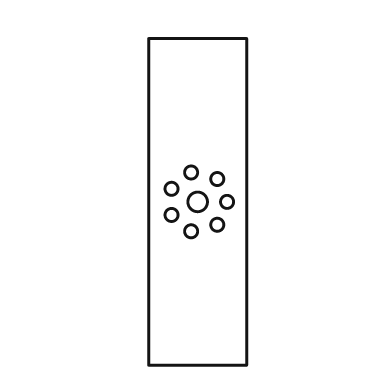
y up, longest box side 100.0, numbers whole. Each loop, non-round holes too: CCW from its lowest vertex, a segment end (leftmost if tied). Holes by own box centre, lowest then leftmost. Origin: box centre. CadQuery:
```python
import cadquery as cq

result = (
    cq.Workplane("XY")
    .moveTo(-15.0, -50.0)
    .lineTo(15.0, -50.0)
    .lineTo(15.0, 50.0)
    .lineTo(-15.0, 50.0)
    .close()
    .moveTo(-2.0, -9.0)
    .circle(2.0)
    .moveTo(6.0, -7.0)
    .circle(2.0)
    .moveTo(-8.0, -4.0)
    .circle(2.0)
    .moveTo(0.0, 0.0)
    .circle(3.0)
    .moveTo(9.0, 0.0)
    .circle(2.0)
    .moveTo(-8.0, 4.0)
    .circle(2.0)
    .moveTo(6.0, 7.0)
    .circle(2.0)
    .moveTo(-2.0, 9.0)
    .circle(2.0)
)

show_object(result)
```